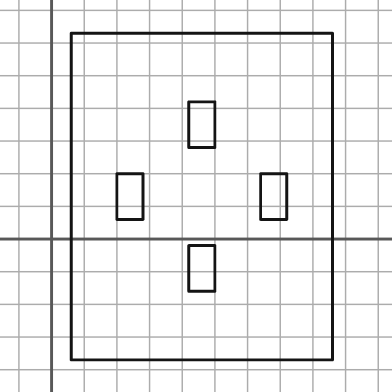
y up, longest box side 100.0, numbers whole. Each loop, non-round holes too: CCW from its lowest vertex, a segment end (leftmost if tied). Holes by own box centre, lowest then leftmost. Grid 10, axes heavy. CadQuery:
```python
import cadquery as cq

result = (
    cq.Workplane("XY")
    .moveTo(6.0, -37.0)
    .lineTo(86.0, -37.0)
    .lineTo(86.0, 63.0)
    .lineTo(6.0, 63.0)
    .close()
    .moveTo(42.0, -16.0)
    .lineTo(50.0, -16.0)
    .lineTo(50.0, -2.0)
    .lineTo(42.0, -2.0)
    .close()
    .moveTo(20.0, 6.0)
    .lineTo(28.0, 6.0)
    .lineTo(28.0, 20.0)
    .lineTo(20.0, 20.0)
    .close()
    .moveTo(64.0, 6.0)
    .lineTo(72.0, 6.0)
    .lineTo(72.0, 20.0)
    .lineTo(64.0, 20.0)
    .close()
    .moveTo(42.0, 28.0)
    .lineTo(50.0, 28.0)
    .lineTo(50.0, 42.0)
    .lineTo(42.0, 42.0)
    .close()
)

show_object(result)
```